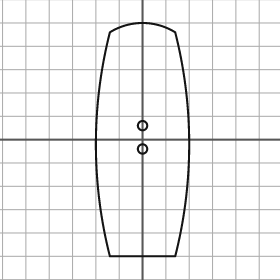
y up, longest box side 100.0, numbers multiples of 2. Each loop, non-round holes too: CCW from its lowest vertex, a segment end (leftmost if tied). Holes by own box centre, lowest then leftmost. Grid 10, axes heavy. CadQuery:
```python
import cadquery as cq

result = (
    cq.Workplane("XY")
    .moveTo(-14.0, -50.0)
    .lineTo(14.0, -50.0)
    .threePointArc((20.0, -2.0), (14.0, 46.0))
    .threePointArc((0.0, 50.0), (-14.0, 46.0))
    .threePointArc((-20.0, -2.0), (-14.0, -50.0))
    .close()
    .moveTo(0.0, -4.0)
    .circle(2.0)
    .moveTo(0.0, 6.0)
    .circle(2.0)
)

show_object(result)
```